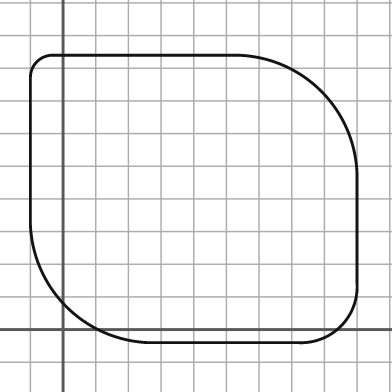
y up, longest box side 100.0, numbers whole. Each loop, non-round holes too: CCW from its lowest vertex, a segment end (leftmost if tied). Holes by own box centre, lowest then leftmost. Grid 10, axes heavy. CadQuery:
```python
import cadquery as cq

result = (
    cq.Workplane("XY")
    .moveTo(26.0, -4.0)
    .lineTo(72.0, -4.0)
    .threePointArc((85.0, 1.0), (90.0, 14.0))
    .lineTo(90.0, 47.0)
    .threePointArc((79.0, 73.0), (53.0, 84.0))
    .lineTo(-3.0, 84.0)
    .threePointArc((-8.0, 82.0), (-10.0, 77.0))
    .lineTo(-10.0, 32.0)
    .threePointArc((1.0, 7.0), (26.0, -4.0))
    .close()
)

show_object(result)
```